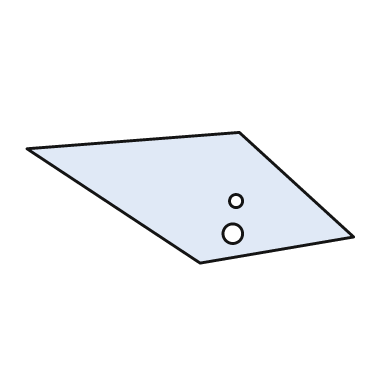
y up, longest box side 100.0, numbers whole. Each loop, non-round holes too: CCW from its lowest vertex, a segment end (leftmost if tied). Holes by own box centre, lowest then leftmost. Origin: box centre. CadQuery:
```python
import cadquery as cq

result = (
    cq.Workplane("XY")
    .moveTo(3.0, -20.0)
    .lineTo(50.0, -12.0)
    .lineTo(15.0, 20.0)
    .lineTo(-50.0, 15.0)
    .close()
    .moveTo(13.0, -11.0)
    .circle(3.0)
    .moveTo(14.0, -1.0)
    .circle(2.0)
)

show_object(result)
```